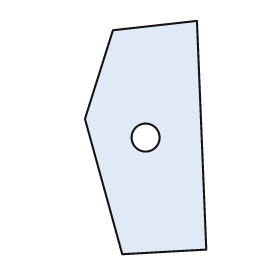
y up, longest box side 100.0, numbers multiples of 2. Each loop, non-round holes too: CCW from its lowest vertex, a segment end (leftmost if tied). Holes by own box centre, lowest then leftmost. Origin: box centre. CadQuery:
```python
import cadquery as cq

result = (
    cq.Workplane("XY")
    .moveTo(-10.0, -50.0)
    .lineTo(26.0, -48.0)
    .lineTo(22.0, 50.0)
    .lineTo(-14.0, 46.0)
    .lineTo(-26.0, 8.0)
    .close()
    .moveTo(0.0, 0.0)
    .circle(6.0)
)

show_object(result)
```